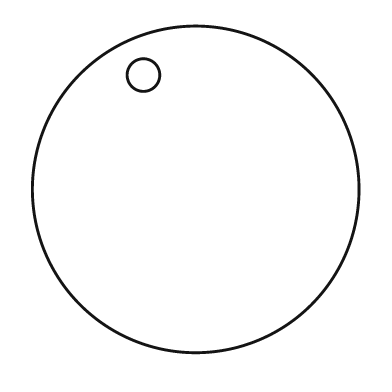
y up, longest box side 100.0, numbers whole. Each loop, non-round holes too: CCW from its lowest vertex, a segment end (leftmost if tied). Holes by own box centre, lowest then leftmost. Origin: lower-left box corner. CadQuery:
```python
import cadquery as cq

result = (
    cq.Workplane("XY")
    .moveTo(50.0, 50.0)
    .circle(50.0)
    .moveTo(34.0, 85.0)
    .circle(5.0)
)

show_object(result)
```